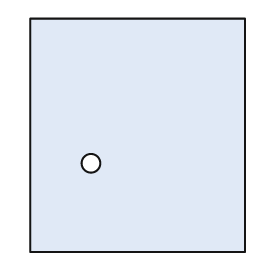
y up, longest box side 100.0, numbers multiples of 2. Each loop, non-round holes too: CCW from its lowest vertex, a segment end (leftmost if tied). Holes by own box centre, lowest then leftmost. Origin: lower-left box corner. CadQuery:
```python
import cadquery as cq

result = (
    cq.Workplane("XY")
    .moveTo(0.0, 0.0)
    .lineTo(92.0, 0.0)
    .lineTo(92.0, 100.0)
    .lineTo(0.0, 100.0)
    .close()
    .moveTo(26.0, 38.0)
    .circle(4.0)
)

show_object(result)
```